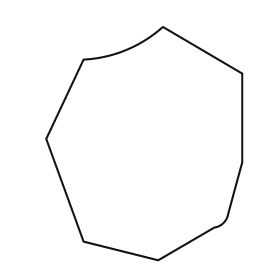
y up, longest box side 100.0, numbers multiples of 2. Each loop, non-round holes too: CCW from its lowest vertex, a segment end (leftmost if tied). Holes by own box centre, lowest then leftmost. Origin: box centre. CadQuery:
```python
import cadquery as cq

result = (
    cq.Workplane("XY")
    .moveTo(6.0, -50.0)
    .lineTo(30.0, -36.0)
    .threePointArc((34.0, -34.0), (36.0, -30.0))
    .lineTo(42.0, -8.0)
    .lineTo(42.0, 30.0)
    .lineTo(8.0, 50.0)
    .threePointArc((-8.0, 40.0), (-26.0, 36.0))
    .lineTo(-42.0, 2.0)
    .lineTo(-26.0, -42.0)
    .close()
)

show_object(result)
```